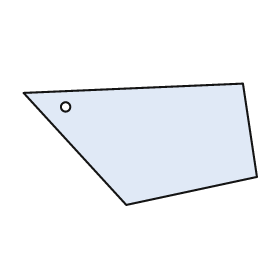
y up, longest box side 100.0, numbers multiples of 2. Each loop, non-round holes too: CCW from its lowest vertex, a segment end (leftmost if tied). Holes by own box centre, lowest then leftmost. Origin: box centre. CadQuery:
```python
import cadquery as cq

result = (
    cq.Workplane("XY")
    .moveTo(-6.0, -26.0)
    .lineTo(50.0, -14.0)
    .lineTo(44.0, 26.0)
    .lineTo(-50.0, 22.0)
    .close()
    .moveTo(-32.0, 16.0)
    .circle(2.0)
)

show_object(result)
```